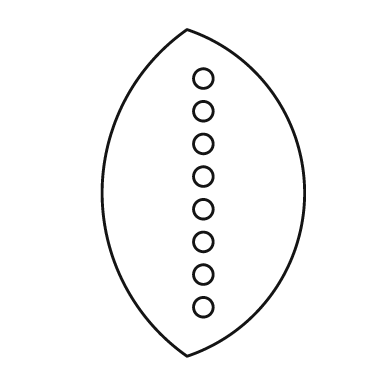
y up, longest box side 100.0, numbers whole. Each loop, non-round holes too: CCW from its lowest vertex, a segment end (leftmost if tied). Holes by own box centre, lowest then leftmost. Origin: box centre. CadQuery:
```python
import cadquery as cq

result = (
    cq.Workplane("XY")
    .moveTo(-5.0, -50.0)
    .threePointArc((31.0, 0.0), (-5.0, 50.0))
    .threePointArc((-31.0, 0.0), (-5.0, -50.0))
    .close()
    .moveTo(0.0, -35.0)
    .circle(3.0)
    .moveTo(0.0, -25.0)
    .circle(3.0)
    .moveTo(0.0, -15.0)
    .circle(3.0)
    .moveTo(0.0, -5.0)
    .circle(3.0)
    .moveTo(0.0, 5.0)
    .circle(3.0)
    .moveTo(0.0, 15.0)
    .circle(3.0)
    .moveTo(0.0, 25.0)
    .circle(3.0)
    .moveTo(0.0, 35.0)
    .circle(3.0)
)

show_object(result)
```